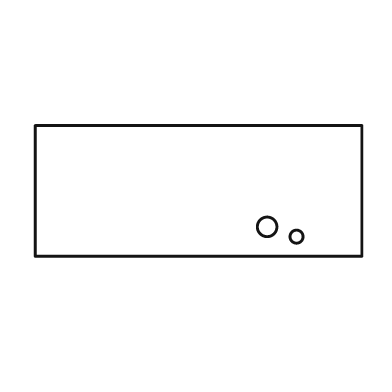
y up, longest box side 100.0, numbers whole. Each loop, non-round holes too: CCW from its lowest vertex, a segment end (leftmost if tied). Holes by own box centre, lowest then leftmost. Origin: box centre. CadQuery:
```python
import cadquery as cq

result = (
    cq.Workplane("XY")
    .moveTo(-50.0, -20.0)
    .lineTo(50.0, -20.0)
    .lineTo(50.0, 20.0)
    .lineTo(-50.0, 20.0)
    .close()
    .moveTo(30.0, -14.0)
    .circle(2.0)
    .moveTo(21.0, -11.0)
    .circle(3.0)
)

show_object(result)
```